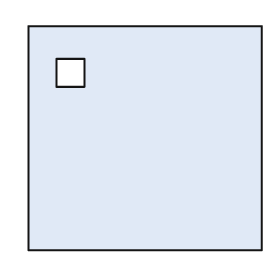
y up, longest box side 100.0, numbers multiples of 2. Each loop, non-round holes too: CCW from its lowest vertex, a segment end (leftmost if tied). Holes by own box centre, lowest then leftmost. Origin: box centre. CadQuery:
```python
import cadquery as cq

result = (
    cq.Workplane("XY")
    .moveTo(-50.0, -48.0)
    .lineTo(50.0, -48.0)
    .lineTo(50.0, 48.0)
    .lineTo(-50.0, 48.0)
    .close()
    .moveTo(-38.0, 22.0)
    .lineTo(-26.0, 22.0)
    .lineTo(-26.0, 34.0)
    .lineTo(-38.0, 34.0)
    .close()
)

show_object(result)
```